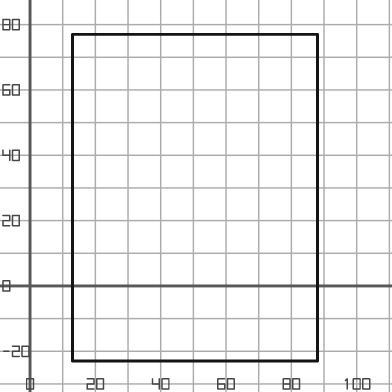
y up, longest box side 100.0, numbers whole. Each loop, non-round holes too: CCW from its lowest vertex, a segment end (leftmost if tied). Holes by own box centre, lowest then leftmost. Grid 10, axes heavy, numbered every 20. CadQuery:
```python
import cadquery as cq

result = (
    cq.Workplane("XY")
    .moveTo(13.0, -23.0)
    .lineTo(88.0, -23.0)
    .lineTo(88.0, 77.0)
    .lineTo(13.0, 77.0)
    .close()
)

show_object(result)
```